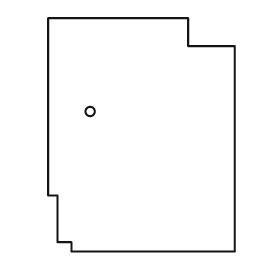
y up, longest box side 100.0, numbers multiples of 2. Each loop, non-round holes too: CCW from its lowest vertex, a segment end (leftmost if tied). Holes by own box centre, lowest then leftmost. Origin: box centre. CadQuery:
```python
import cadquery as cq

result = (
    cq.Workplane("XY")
    .moveTo(-30.0, -50.0)
    .lineTo(40.0, -50.0)
    .lineTo(40.0, 38.0)
    .lineTo(20.0, 38.0)
    .lineTo(20.0, 50.0)
    .lineTo(-40.0, 50.0)
    .lineTo(-40.0, -26.0)
    .lineTo(-36.0, -26.0)
    .lineTo(-36.0, -46.0)
    .lineTo(-30.0, -46.0)
    .close()
    .moveTo(-22.0, 10.0)
    .circle(2.0)
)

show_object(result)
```